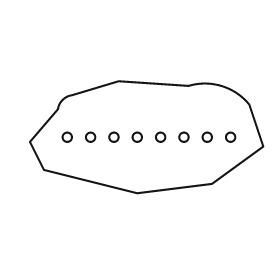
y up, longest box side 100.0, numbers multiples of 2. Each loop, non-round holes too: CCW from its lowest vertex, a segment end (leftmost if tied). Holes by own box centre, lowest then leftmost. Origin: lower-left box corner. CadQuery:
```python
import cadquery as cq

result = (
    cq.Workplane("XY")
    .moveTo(46.0, 0.0)
    .lineTo(78.0, 4.0)
    .lineTo(100.0, 20.0)
    .lineTo(94.0, 38.0)
    .threePointArc((82.0, 46.0), (68.0, 46.0))
    .lineTo(38.0, 48.0)
    .lineTo(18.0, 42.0)
    .threePointArc((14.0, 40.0), (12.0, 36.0))
    .lineTo(0.0, 22.0)
    .lineTo(6.0, 10.0)
    .close()
    .moveTo(16.0, 24.0)
    .circle(2.0)
    .moveTo(26.0, 24.0)
    .circle(2.0)
    .moveTo(36.0, 24.0)
    .circle(2.0)
    .moveTo(46.0, 24.0)
    .circle(2.0)
    .moveTo(56.0, 24.0)
    .circle(2.0)
    .moveTo(66.0, 24.0)
    .circle(2.0)
    .moveTo(76.0, 24.0)
    .circle(2.0)
    .moveTo(86.0, 24.0)
    .circle(2.0)
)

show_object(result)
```